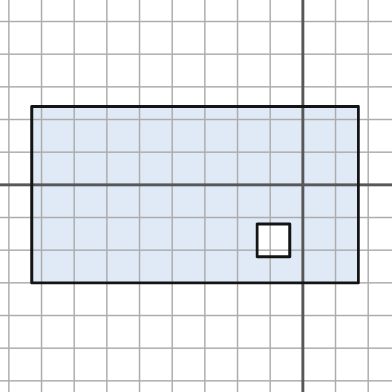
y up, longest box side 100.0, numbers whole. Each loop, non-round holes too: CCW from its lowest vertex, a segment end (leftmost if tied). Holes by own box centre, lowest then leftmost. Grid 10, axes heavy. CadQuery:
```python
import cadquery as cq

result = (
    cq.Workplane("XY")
    .moveTo(-83.0, -30.0)
    .lineTo(17.0, -30.0)
    .lineTo(17.0, 24.0)
    .lineTo(-83.0, 24.0)
    .close()
    .moveTo(-14.0, -22.0)
    .lineTo(-4.0, -22.0)
    .lineTo(-4.0, -12.0)
    .lineTo(-14.0, -12.0)
    .close()
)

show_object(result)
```